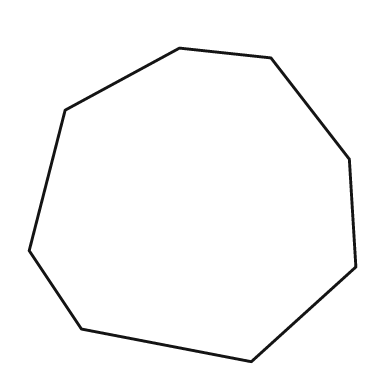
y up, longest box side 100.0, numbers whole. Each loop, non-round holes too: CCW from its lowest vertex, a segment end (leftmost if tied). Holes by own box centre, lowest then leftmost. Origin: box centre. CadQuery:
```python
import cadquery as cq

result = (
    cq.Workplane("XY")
    .moveTo(18.0, -48.0)
    .lineTo(50.0, -19.0)
    .lineTo(48.0, 14.0)
    .lineTo(24.0, 45.0)
    .lineTo(-4.0, 48.0)
    .lineTo(-39.0, 29.0)
    .lineTo(-50.0, -14.0)
    .lineTo(-34.0, -38.0)
    .close()
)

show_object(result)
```